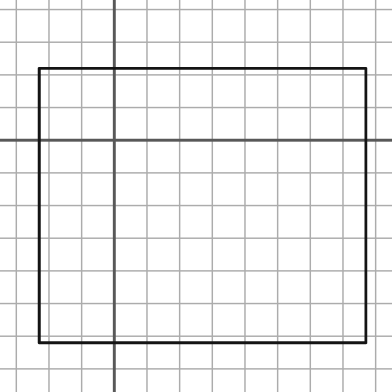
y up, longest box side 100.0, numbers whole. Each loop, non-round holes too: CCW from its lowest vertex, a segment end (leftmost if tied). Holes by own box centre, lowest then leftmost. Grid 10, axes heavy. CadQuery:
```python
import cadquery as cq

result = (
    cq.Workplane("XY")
    .moveTo(-23.0, -62.0)
    .lineTo(77.0, -62.0)
    .lineTo(77.0, 22.0)
    .lineTo(-23.0, 22.0)
    .close()
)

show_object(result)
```